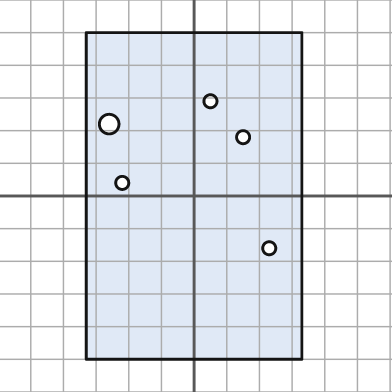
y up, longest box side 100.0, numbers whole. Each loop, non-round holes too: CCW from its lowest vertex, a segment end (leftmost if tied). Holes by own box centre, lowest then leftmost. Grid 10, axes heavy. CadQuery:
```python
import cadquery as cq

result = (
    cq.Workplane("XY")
    .moveTo(-33.0, -50.0)
    .lineTo(33.0, -50.0)
    .lineTo(33.0, 50.0)
    .lineTo(-33.0, 50.0)
    .close()
    .moveTo(23.0, -16.0)
    .circle(2.0)
    .moveTo(-22.0, 4.0)
    .circle(2.0)
    .moveTo(15.0, 18.0)
    .circle(2.0)
    .moveTo(-26.0, 22.0)
    .circle(3.0)
    .moveTo(5.0, 29.0)
    .circle(2.0)
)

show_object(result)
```